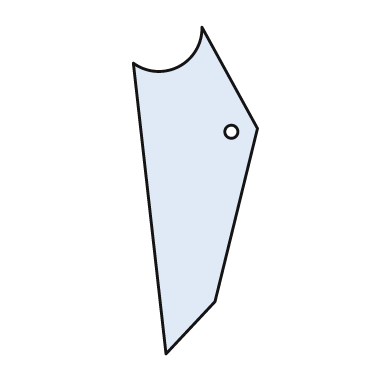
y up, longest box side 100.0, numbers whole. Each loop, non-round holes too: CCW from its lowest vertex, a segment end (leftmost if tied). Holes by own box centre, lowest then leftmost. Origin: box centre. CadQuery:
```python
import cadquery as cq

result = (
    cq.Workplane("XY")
    .moveTo(-9.0, -50.0)
    .lineTo(6.0, -34.0)
    .lineTo(19.0, 19.0)
    .lineTo(2.0, 50.0)
    .threePointArc((-5.0, 38.0), (-19.0, 39.0))
    .close()
    .moveTo(11.0, 18.0)
    .circle(2.0)
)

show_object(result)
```